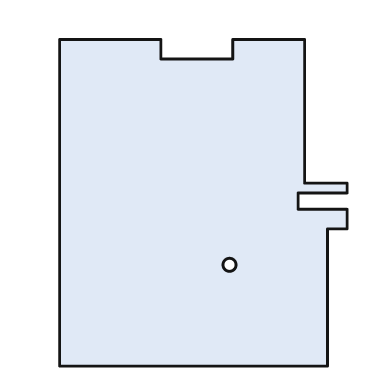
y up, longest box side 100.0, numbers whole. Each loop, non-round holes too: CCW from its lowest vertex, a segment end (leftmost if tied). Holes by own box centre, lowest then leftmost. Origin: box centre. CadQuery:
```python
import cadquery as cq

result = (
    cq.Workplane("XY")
    .moveTo(-44.0, -50.0)
    .lineTo(38.0, -50.0)
    .lineTo(38.0, -8.0)
    .lineTo(44.0, -8.0)
    .lineTo(44.0, -2.0)
    .lineTo(29.0, -2.0)
    .lineTo(29.0, 3.0)
    .lineTo(44.0, 3.0)
    .lineTo(44.0, 6.0)
    .lineTo(31.0, 6.0)
    .lineTo(31.0, 50.0)
    .lineTo(9.0, 50.0)
    .lineTo(9.0, 44.0)
    .lineTo(-13.0, 44.0)
    .lineTo(-13.0, 50.0)
    .lineTo(-44.0, 50.0)
    .close()
    .moveTo(8.0, -19.0)
    .circle(2.0)
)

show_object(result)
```